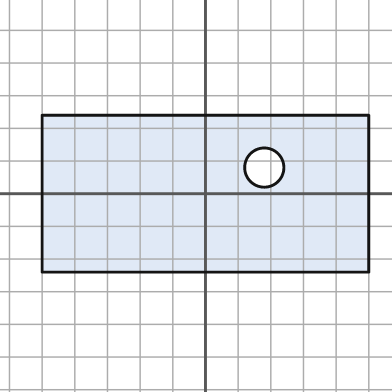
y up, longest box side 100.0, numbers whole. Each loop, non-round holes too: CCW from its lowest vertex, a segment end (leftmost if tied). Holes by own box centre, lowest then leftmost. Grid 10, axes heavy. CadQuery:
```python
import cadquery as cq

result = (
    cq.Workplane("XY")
    .moveTo(-50.0, -24.0)
    .lineTo(50.0, -24.0)
    .lineTo(50.0, 24.0)
    .lineTo(-50.0, 24.0)
    .close()
    .moveTo(18.0, 8.0)
    .circle(6.0)
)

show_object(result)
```